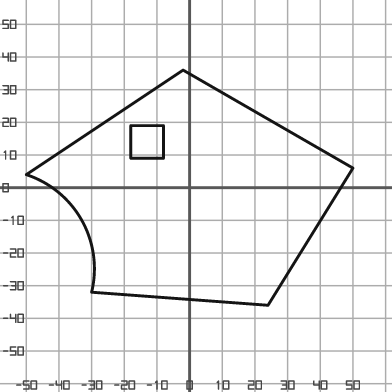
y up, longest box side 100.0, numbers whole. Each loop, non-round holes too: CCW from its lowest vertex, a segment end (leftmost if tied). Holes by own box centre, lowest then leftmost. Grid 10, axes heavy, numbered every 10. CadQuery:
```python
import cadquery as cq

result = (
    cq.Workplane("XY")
    .moveTo(24.0, -36.0)
    .lineTo(50.0, 6.0)
    .lineTo(-2.0, 36.0)
    .lineTo(-50.0, 4.0)
    .threePointArc((-33.0, -10.0), (-30.0, -32.0))
    .close()
    .moveTo(-18.0, 9.0)
    .lineTo(-8.0, 9.0)
    .lineTo(-8.0, 19.0)
    .lineTo(-18.0, 19.0)
    .close()
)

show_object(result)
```